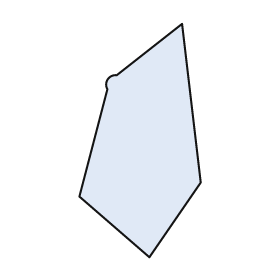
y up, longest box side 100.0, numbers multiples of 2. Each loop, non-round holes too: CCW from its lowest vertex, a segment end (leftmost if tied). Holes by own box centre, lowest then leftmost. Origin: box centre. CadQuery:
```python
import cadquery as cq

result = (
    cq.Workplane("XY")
    .moveTo(4.0, -50.0)
    .lineTo(26.0, -18.0)
    .lineTo(18.0, 50.0)
    .lineTo(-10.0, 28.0)
    .threePointArc((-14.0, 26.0), (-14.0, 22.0))
    .lineTo(-26.0, -24.0)
    .close()
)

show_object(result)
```